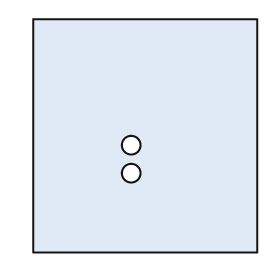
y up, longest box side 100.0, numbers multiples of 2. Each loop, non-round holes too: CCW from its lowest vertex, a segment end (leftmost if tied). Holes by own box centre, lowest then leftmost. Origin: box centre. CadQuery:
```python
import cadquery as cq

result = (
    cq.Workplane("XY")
    .moveTo(-48.0, -50.0)
    .lineTo(48.0, -50.0)
    .lineTo(48.0, 50.0)
    .lineTo(-48.0, 50.0)
    .close()
    .moveTo(-6.0, -16.0)
    .circle(4.0)
    .moveTo(-6.0, -4.0)
    .circle(4.0)
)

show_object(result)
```